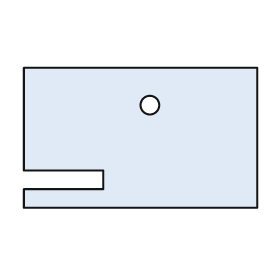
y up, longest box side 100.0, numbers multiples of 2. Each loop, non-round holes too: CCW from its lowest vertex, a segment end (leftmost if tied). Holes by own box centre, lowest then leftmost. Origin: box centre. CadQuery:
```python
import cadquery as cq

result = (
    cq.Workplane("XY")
    .moveTo(-50.0, -30.0)
    .lineTo(50.0, -30.0)
    .lineTo(50.0, 30.0)
    .lineTo(-50.0, 30.0)
    .lineTo(-50.0, -14.0)
    .lineTo(-16.0, -14.0)
    .lineTo(-16.0, -22.0)
    .lineTo(-50.0, -22.0)
    .close()
    .moveTo(4.0, 14.0)
    .circle(4.0)
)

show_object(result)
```